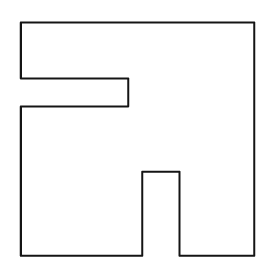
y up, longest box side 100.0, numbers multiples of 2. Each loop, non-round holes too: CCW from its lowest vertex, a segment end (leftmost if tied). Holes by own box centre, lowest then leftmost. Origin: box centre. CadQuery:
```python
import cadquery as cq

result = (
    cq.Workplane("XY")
    .moveTo(-50.0, -50.0)
    .lineTo(2.0, -50.0)
    .lineTo(2.0, -14.0)
    .lineTo(18.0, -14.0)
    .lineTo(18.0, -50.0)
    .lineTo(50.0, -50.0)
    .lineTo(50.0, 50.0)
    .lineTo(-50.0, 50.0)
    .lineTo(-50.0, 26.0)
    .lineTo(-4.0, 26.0)
    .lineTo(-4.0, 14.0)
    .lineTo(-50.0, 14.0)
    .close()
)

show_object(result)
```